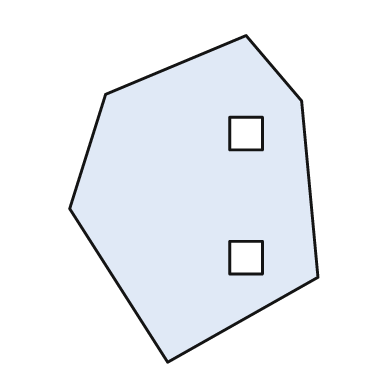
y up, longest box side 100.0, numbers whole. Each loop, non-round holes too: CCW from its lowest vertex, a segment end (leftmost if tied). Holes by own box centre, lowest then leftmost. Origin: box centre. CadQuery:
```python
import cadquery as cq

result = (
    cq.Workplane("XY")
    .moveTo(-8.0, -50.0)
    .lineTo(38.0, -24.0)
    .lineTo(33.0, 30.0)
    .lineTo(16.0, 50.0)
    .lineTo(-27.0, 32.0)
    .lineTo(-38.0, -3.0)
    .close()
    .moveTo(11.0, -23.0)
    .lineTo(21.0, -23.0)
    .lineTo(21.0, -13.0)
    .lineTo(11.0, -13.0)
    .close()
    .moveTo(11.0, 15.0)
    .lineTo(21.0, 15.0)
    .lineTo(21.0, 25.0)
    .lineTo(11.0, 25.0)
    .close()
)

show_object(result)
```